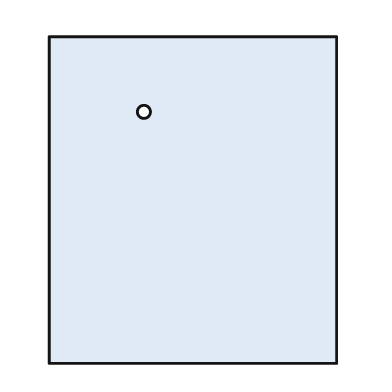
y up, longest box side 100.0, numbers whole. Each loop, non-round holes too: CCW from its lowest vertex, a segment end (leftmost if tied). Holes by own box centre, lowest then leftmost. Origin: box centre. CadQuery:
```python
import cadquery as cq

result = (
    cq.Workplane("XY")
    .moveTo(-44.0, -50.0)
    .lineTo(44.0, -50.0)
    .lineTo(44.0, 50.0)
    .lineTo(-44.0, 50.0)
    .close()
    .moveTo(-15.0, 27.0)
    .circle(2.0)
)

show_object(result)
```